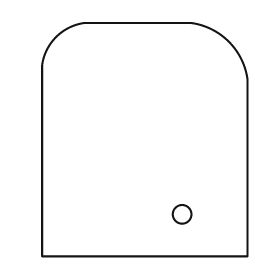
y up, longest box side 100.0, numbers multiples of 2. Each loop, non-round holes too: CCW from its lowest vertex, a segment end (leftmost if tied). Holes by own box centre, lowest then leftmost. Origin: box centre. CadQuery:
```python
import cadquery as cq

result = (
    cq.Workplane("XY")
    .moveTo(-44.0, -50.0)
    .lineTo(44.0, -50.0)
    .lineTo(44.0, 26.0)
    .threePointArc((36.0, 42.0), (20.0, 50.0))
    .lineTo(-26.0, 50.0)
    .threePointArc((-38.0, 44.0), (-44.0, 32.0))
    .close()
    .moveTo(16.0, -32.0)
    .circle(4.0)
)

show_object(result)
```